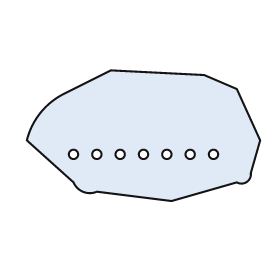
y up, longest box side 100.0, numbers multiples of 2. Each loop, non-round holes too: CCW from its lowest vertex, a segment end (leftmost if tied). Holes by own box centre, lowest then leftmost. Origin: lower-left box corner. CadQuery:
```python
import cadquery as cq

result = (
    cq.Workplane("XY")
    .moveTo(62.0, 0.0)
    .lineTo(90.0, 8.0)
    .threePointArc((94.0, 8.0), (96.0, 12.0))
    .lineTo(100.0, 26.0)
    .lineTo(90.0, 48.0)
    .lineTo(76.0, 54.0)
    .lineTo(36.0, 56.0)
    .lineTo(16.0, 46.0)
    .threePointArc((6.0, 38.0), (0.0, 26.0))
    .lineTo(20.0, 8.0)
    .threePointArc((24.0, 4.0), (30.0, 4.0))
    .close()
    .moveTo(20.0, 20.0)
    .circle(2.0)
    .moveTo(30.0, 20.0)
    .circle(2.0)
    .moveTo(40.0, 20.0)
    .circle(2.0)
    .moveTo(50.0, 20.0)
    .circle(2.0)
    .moveTo(60.0, 20.0)
    .circle(2.0)
    .moveTo(70.0, 20.0)
    .circle(2.0)
    .moveTo(80.0, 20.0)
    .circle(2.0)
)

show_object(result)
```